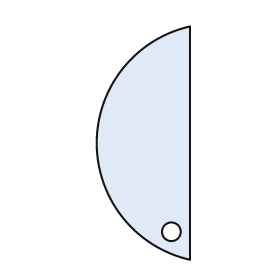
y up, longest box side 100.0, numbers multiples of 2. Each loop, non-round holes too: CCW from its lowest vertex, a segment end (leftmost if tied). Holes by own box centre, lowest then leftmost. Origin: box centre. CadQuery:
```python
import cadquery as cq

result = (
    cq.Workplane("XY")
    .moveTo(20.0, -50.0)
    .lineTo(20.0, 50.0)
    .threePointArc((-20.0, 0.0), (20.0, -50.0))
    .close()
    .moveTo(12.0, -38.0)
    .circle(4.0)
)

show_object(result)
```